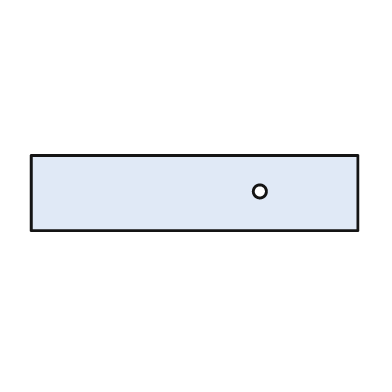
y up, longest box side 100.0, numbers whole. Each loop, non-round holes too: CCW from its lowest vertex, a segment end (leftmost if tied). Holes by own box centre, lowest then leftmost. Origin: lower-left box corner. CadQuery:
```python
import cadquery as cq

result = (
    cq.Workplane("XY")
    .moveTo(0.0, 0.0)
    .lineTo(100.0, 0.0)
    .lineTo(100.0, 23.0)
    .lineTo(0.0, 23.0)
    .close()
    .moveTo(70.0, 12.0)
    .circle(2.0)
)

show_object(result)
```